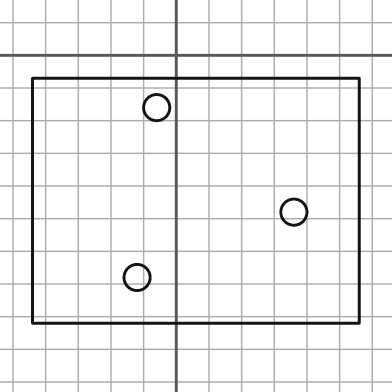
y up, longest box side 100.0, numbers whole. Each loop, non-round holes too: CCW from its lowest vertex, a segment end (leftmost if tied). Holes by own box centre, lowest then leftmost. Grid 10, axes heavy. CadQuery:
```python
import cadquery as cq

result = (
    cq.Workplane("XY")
    .moveTo(-44.0, -82.0)
    .lineTo(56.0, -82.0)
    .lineTo(56.0, -7.0)
    .lineTo(-44.0, -7.0)
    .close()
    .moveTo(-12.0, -68.0)
    .circle(4.0)
    .moveTo(36.0, -48.0)
    .circle(4.0)
    .moveTo(-6.0, -16.0)
    .circle(4.0)
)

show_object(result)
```